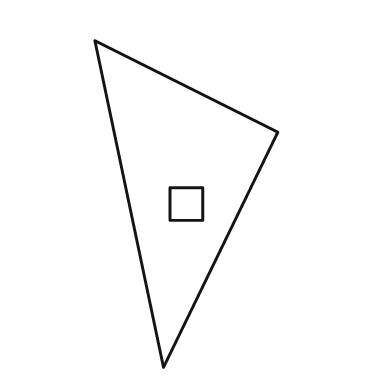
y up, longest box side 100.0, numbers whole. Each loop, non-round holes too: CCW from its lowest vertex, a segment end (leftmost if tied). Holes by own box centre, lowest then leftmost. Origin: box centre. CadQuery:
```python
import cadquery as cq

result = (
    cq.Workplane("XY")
    .moveTo(-7.0, -50.0)
    .lineTo(28.0, 22.0)
    .lineTo(-28.0, 50.0)
    .close()
    .moveTo(-5.0, -5.0)
    .lineTo(5.0, -5.0)
    .lineTo(5.0, 5.0)
    .lineTo(-5.0, 5.0)
    .close()
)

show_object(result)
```